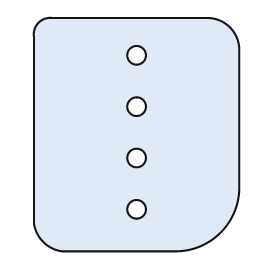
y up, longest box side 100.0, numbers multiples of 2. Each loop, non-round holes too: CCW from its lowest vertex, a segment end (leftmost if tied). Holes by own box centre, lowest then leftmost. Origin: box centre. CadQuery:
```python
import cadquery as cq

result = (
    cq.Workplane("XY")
    .moveTo(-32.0, -50.0)
    .lineTo(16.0, -50.0)
    .threePointArc((36.0, -42.0), (44.0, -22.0))
    .lineTo(44.0, 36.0)
    .threePointArc((40.0, 46.0), (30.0, 50.0))
    .lineTo(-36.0, 50.0)
    .threePointArc((-42.0, 48.0), (-44.0, 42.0))
    .lineTo(-44.0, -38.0)
    .threePointArc((-40.0, -46.0), (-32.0, -50.0))
    .close()
    .moveTo(0.0, -32.0)
    .circle(4.0)
    .moveTo(0.0, -10.0)
    .circle(4.0)
    .moveTo(0.0, 12.0)
    .circle(4.0)
    .moveTo(0.0, 34.0)
    .circle(4.0)
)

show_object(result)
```